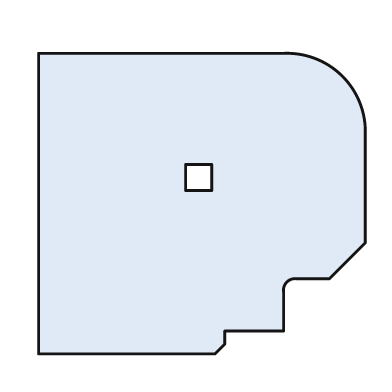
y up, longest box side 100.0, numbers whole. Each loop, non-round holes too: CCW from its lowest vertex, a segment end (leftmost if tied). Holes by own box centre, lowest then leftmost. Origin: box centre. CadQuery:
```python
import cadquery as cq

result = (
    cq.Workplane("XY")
    .moveTo(-50.0, -46.0)
    .lineTo(4.0, -46.0)
    .lineTo(7.0, -43.0)
    .lineTo(7.0, -39.0)
    .lineTo(25.0, -39.0)
    .lineTo(25.0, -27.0)
    .threePointArc((26.0, -24.0), (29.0, -23.0))
    .lineTo(39.0, -23.0)
    .lineTo(50.0, -12.0)
    .lineTo(50.0, 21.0)
    .threePointArc((43.0, 39.0), (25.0, 46.0))
    .lineTo(-50.0, 46.0)
    .close()
    .moveTo(-5.0, 4.0)
    .lineTo(3.0, 4.0)
    .lineTo(3.0, 12.0)
    .lineTo(-5.0, 12.0)
    .close()
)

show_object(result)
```